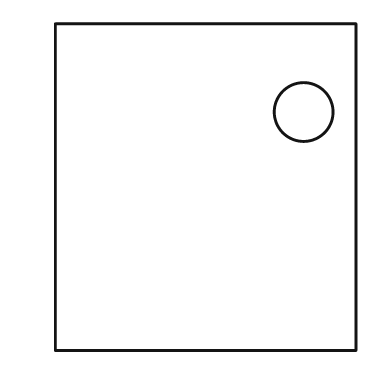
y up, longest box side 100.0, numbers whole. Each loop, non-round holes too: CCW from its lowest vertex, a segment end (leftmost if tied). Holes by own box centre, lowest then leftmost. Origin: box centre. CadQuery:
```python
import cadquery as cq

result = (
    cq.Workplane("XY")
    .moveTo(-46.0, -50.0)
    .lineTo(46.0, -50.0)
    .lineTo(46.0, 50.0)
    .lineTo(-46.0, 50.0)
    .close()
    .moveTo(30.0, 23.0)
    .circle(9.0)
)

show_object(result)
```